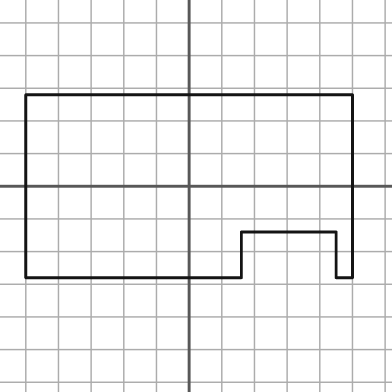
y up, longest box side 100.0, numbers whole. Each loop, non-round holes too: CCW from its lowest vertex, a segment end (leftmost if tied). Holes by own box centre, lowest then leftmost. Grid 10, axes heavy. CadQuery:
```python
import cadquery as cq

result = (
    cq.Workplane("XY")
    .moveTo(-50.0, -28.0)
    .lineTo(16.0, -28.0)
    .lineTo(16.0, -14.0)
    .lineTo(45.0, -14.0)
    .lineTo(45.0, -28.0)
    .lineTo(50.0, -28.0)
    .lineTo(50.0, 28.0)
    .lineTo(-50.0, 28.0)
    .close()
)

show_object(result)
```